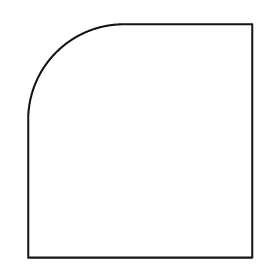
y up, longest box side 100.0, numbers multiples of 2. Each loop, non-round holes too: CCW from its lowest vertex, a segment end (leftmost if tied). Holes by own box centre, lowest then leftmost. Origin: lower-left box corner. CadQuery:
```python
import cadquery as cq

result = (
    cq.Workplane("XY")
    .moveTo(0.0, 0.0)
    .lineTo(96.0, 0.0)
    .lineTo(96.0, 100.0)
    .lineTo(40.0, 100.0)
    .threePointArc((12.0, 88.0), (0.0, 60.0))
    .close()
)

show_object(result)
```